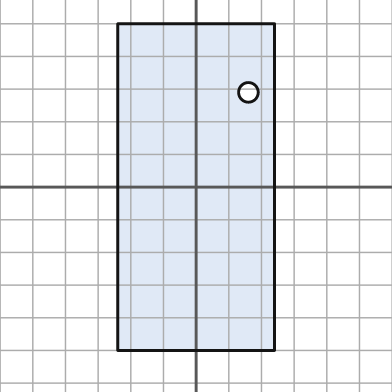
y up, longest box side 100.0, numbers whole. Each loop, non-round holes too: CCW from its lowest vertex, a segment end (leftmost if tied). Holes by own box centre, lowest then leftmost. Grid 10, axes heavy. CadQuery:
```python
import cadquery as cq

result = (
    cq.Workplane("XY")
    .moveTo(-24.0, -50.0)
    .lineTo(24.0, -50.0)
    .lineTo(24.0, 50.0)
    .lineTo(-24.0, 50.0)
    .close()
    .moveTo(16.0, 29.0)
    .circle(3.0)
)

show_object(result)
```